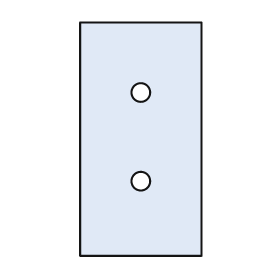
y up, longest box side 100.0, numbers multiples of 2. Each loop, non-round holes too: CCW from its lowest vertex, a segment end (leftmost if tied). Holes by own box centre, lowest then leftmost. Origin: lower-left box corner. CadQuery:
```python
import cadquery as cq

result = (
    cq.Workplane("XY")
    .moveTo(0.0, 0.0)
    .lineTo(52.0, 0.0)
    .lineTo(52.0, 100.0)
    .lineTo(0.0, 100.0)
    .close()
    .moveTo(26.0, 32.0)
    .circle(4.0)
    .moveTo(26.0, 70.0)
    .circle(4.0)
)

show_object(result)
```